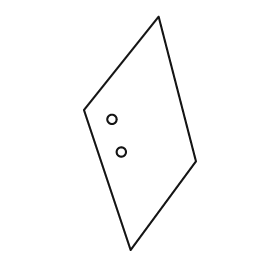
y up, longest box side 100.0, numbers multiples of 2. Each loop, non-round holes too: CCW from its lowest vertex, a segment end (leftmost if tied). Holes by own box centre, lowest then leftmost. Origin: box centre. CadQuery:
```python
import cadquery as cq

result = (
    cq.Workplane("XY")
    .moveTo(-4.0, -50.0)
    .lineTo(24.0, -12.0)
    .lineTo(8.0, 50.0)
    .lineTo(-24.0, 10.0)
    .close()
    .moveTo(-8.0, -8.0)
    .circle(2.0)
    .moveTo(-12.0, 6.0)
    .circle(2.0)
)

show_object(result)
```